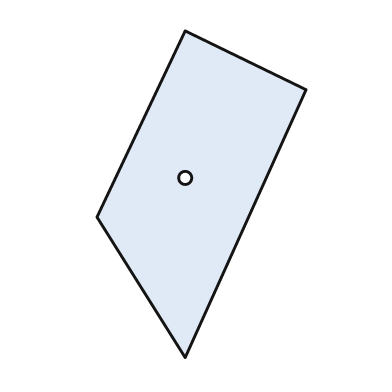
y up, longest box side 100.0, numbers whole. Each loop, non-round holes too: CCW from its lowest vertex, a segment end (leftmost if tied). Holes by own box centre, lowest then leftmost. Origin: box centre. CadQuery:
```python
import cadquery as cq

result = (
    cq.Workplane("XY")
    .moveTo(-5.0, -50.0)
    .lineTo(32.0, 32.0)
    .lineTo(-5.0, 50.0)
    .lineTo(-32.0, -7.0)
    .close()
    .moveTo(-5.0, 5.0)
    .circle(2.0)
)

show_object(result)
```